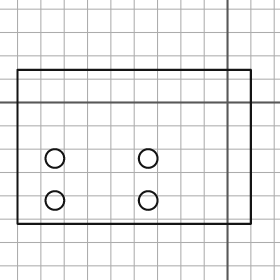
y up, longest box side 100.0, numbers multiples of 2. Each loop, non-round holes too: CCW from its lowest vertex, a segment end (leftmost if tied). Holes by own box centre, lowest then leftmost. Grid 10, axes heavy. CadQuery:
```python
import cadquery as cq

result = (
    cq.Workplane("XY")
    .moveTo(-90.0, -52.0)
    .lineTo(10.0, -52.0)
    .lineTo(10.0, 14.0)
    .lineTo(-90.0, 14.0)
    .close()
    .moveTo(-74.0, -42.0)
    .circle(4.0)
    .moveTo(-34.0, -42.0)
    .circle(4.0)
    .moveTo(-74.0, -24.0)
    .circle(4.0)
    .moveTo(-34.0, -24.0)
    .circle(4.0)
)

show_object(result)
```